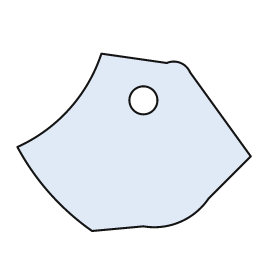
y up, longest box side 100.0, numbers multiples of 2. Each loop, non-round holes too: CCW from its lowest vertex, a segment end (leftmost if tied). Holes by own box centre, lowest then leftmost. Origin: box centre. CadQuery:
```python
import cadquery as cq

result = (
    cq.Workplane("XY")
    .moveTo(-18.0, -38.0)
    .lineTo(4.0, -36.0)
    .threePointArc((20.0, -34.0), (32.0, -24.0))
    .lineTo(50.0, -6.0)
    .lineTo(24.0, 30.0)
    .threePointArc((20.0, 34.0), (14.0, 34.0))
    .lineTo(-14.0, 38.0)
    .threePointArc((-28.0, 14.0), (-50.0, -2.0))
    .threePointArc((-36.0, -22.0), (-18.0, -38.0))
    .close()
    .moveTo(4.0, 18.0)
    .circle(6.0)
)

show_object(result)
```